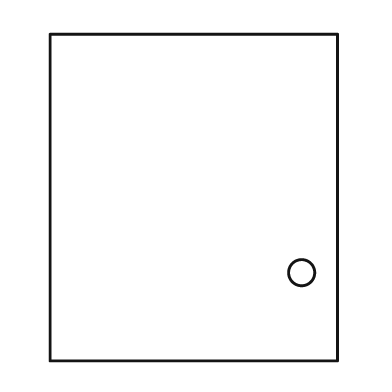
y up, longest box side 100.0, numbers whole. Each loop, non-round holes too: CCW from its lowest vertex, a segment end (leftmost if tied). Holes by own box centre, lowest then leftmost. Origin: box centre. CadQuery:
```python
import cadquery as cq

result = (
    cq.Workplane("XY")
    .moveTo(-44.0, -50.0)
    .lineTo(44.0, -50.0)
    .lineTo(44.0, 50.0)
    .lineTo(-44.0, 50.0)
    .close()
    .moveTo(33.0, -23.0)
    .circle(4.0)
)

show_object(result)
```